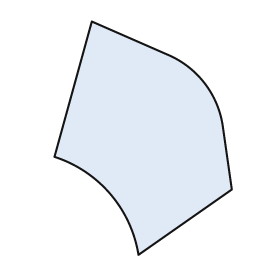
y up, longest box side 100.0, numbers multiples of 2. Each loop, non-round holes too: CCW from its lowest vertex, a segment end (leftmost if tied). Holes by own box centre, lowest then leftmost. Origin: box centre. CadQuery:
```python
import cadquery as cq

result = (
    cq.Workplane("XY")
    .moveTo(-2.0, -50.0)
    .lineTo(38.0, -22.0)
    .lineTo(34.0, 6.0)
    .threePointArc((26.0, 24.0), (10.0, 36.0))
    .lineTo(-22.0, 50.0)
    .lineTo(-38.0, -8.0)
    .threePointArc((-14.0, -24.0), (-2.0, -50.0))
    .close()
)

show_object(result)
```